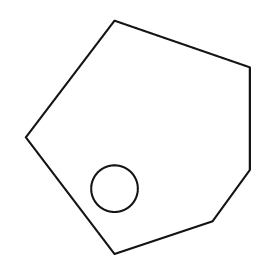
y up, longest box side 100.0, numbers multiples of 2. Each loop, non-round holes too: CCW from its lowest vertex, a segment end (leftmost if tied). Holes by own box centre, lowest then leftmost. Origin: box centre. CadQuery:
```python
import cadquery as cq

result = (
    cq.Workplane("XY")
    .moveTo(-10.0, -50.0)
    .lineTo(32.0, -36.0)
    .lineTo(48.0, -14.0)
    .lineTo(48.0, 30.0)
    .lineTo(-10.0, 50.0)
    .lineTo(-48.0, 0.0)
    .close()
    .moveTo(-10.0, -22.0)
    .circle(10.0)
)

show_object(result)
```